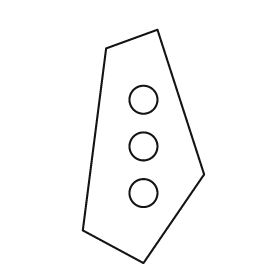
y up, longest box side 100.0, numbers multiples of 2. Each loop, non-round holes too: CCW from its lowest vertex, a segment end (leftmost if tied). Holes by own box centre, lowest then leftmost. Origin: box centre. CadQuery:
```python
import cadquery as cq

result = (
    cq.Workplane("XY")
    .moveTo(0.0, -50.0)
    .lineTo(26.0, -12.0)
    .lineTo(6.0, 50.0)
    .lineTo(-16.0, 42.0)
    .lineTo(-26.0, -36.0)
    .close()
    .moveTo(0.0, -20.0)
    .circle(6.0)
    .moveTo(0.0, 0.0)
    .circle(6.0)
    .moveTo(0.0, 20.0)
    .circle(6.0)
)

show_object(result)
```